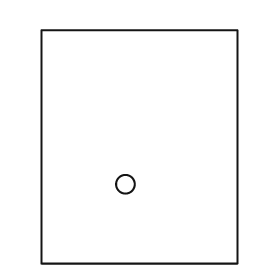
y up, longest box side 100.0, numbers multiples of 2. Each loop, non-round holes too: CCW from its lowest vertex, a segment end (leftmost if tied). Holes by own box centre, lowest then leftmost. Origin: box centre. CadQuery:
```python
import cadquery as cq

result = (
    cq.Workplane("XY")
    .moveTo(-42.0, -50.0)
    .lineTo(42.0, -50.0)
    .lineTo(42.0, 50.0)
    .lineTo(-42.0, 50.0)
    .close()
    .moveTo(-6.0, -16.0)
    .circle(4.0)
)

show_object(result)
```